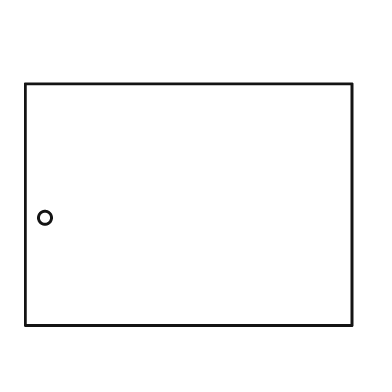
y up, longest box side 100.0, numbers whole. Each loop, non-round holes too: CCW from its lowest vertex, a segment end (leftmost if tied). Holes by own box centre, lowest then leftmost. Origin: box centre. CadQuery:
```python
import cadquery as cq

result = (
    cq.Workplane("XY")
    .moveTo(-50.0, -37.0)
    .lineTo(50.0, -37.0)
    .lineTo(50.0, 37.0)
    .lineTo(-50.0, 37.0)
    .close()
    .moveTo(-44.0, -4.0)
    .circle(2.0)
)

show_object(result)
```